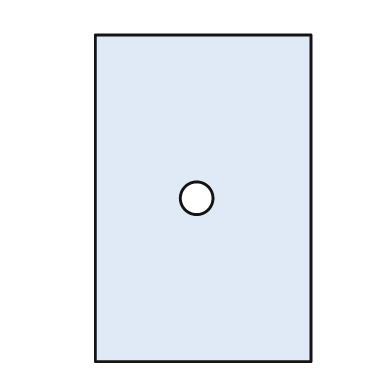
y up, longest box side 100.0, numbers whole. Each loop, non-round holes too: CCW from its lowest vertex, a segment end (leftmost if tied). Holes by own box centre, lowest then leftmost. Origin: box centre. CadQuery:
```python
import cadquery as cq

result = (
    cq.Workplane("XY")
    .moveTo(-33.0, -50.0)
    .lineTo(33.0, -50.0)
    .lineTo(33.0, 50.0)
    .lineTo(-33.0, 50.0)
    .close()
    .moveTo(-2.0, 0.0)
    .circle(5.0)
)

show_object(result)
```